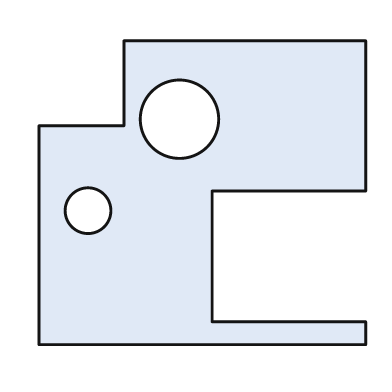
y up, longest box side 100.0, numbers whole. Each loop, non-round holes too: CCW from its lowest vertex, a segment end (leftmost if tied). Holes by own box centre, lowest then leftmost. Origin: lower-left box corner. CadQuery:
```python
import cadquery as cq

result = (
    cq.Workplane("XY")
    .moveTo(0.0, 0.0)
    .lineTo(100.0, 0.0)
    .lineTo(100.0, 7.0)
    .lineTo(53.0, 7.0)
    .lineTo(53.0, 47.0)
    .lineTo(100.0, 47.0)
    .lineTo(100.0, 93.0)
    .lineTo(26.0, 93.0)
    .lineTo(26.0, 67.0)
    .lineTo(0.0, 67.0)
    .close()
    .moveTo(15.0, 41.0)
    .circle(7.0)
    .moveTo(43.0, 69.0)
    .circle(12.0)
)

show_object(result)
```